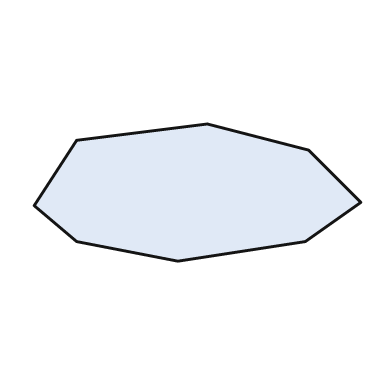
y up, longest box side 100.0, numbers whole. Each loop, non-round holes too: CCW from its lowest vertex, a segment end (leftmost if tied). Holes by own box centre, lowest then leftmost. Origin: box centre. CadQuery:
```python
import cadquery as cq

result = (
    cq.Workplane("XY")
    .moveTo(-6.0, -21.0)
    .lineTo(33.0, -15.0)
    .lineTo(50.0, -3.0)
    .lineTo(34.0, 13.0)
    .lineTo(3.0, 21.0)
    .lineTo(-37.0, 16.0)
    .lineTo(-50.0, -4.0)
    .lineTo(-37.0, -15.0)
    .close()
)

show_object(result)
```